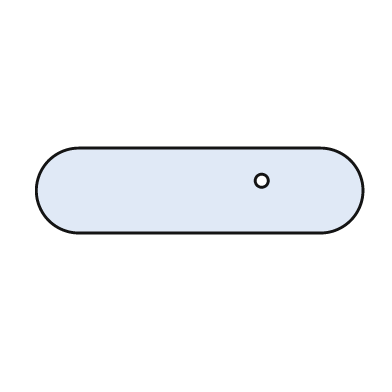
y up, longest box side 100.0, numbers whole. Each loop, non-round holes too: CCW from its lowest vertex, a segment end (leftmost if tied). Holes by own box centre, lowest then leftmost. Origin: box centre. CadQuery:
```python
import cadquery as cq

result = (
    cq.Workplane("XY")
    .moveTo(-37.0, -13.0)
    .lineTo(37.0, -13.0)
    .threePointArc((50.0, 0.0), (37.0, 13.0))
    .lineTo(-37.0, 13.0)
    .threePointArc((-50.0, 0.0), (-37.0, -13.0))
    .close()
    .moveTo(19.0, 3.0)
    .circle(2.0)
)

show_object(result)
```